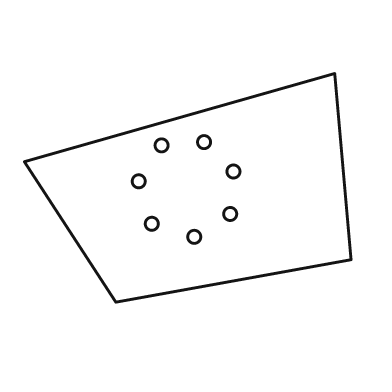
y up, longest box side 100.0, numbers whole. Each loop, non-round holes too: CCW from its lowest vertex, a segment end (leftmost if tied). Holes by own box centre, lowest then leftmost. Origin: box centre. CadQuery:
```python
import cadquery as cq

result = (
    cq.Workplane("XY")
    .moveTo(-22.0, -35.0)
    .lineTo(50.0, -22.0)
    .lineTo(45.0, 35.0)
    .lineTo(-50.0, 8.0)
    .close()
    .moveTo(2.0, -15.0)
    .circle(2.0)
    .moveTo(-11.0, -11.0)
    .circle(2.0)
    .moveTo(13.0, -8.0)
    .circle(2.0)
    .moveTo(-15.0, 2.0)
    .circle(2.0)
    .moveTo(14.0, 5.0)
    .circle(2.0)
    .moveTo(-8.0, 13.0)
    .circle(2.0)
    .moveTo(5.0, 14.0)
    .circle(2.0)
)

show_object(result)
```